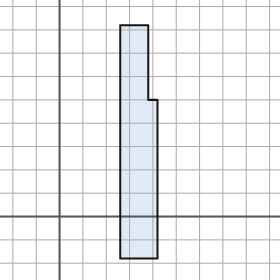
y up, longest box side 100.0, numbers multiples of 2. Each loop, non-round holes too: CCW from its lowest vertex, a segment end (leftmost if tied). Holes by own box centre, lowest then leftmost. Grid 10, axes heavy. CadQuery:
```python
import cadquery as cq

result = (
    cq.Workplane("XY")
    .moveTo(26.0, -18.0)
    .lineTo(42.0, -18.0)
    .lineTo(42.0, 50.0)
    .lineTo(38.0, 50.0)
    .lineTo(38.0, 82.0)
    .lineTo(26.0, 82.0)
    .close()
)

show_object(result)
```